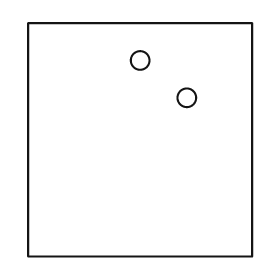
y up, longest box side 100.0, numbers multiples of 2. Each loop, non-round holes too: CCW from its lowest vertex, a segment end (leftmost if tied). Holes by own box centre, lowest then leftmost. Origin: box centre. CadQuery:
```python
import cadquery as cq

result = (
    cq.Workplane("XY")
    .moveTo(-48.0, -50.0)
    .lineTo(48.0, -50.0)
    .lineTo(48.0, 50.0)
    .lineTo(-48.0, 50.0)
    .close()
    .moveTo(20.0, 18.0)
    .circle(4.0)
    .moveTo(0.0, 34.0)
    .circle(4.0)
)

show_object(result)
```